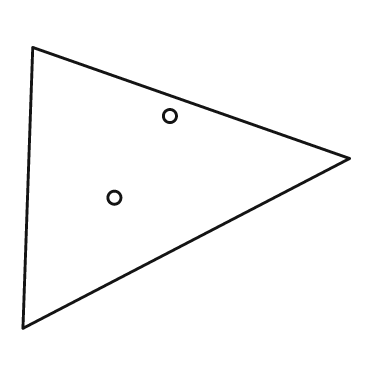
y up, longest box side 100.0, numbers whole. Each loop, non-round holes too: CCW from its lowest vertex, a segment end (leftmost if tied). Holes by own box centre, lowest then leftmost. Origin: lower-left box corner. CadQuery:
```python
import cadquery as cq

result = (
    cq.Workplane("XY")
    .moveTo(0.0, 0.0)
    .lineTo(100.0, 52.0)
    .lineTo(3.0, 86.0)
    .close()
    .moveTo(28.0, 40.0)
    .circle(2.0)
    .moveTo(45.0, 65.0)
    .circle(2.0)
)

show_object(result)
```